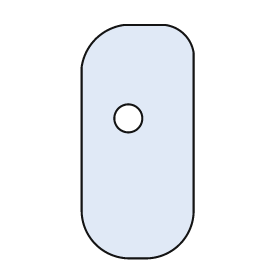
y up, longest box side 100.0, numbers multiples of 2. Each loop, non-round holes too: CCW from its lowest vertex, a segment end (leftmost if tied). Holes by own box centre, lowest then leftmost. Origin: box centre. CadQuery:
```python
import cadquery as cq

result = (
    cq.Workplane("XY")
    .moveTo(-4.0, -50.0)
    .lineTo(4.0, -50.0)
    .threePointArc((18.0, -44.0), (24.0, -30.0))
    .lineTo(24.0, 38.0)
    .threePointArc((20.0, 46.0), (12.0, 50.0))
    .lineTo(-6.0, 50.0)
    .threePointArc((-18.0, 44.0), (-24.0, 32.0))
    .lineTo(-24.0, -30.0)
    .threePointArc((-18.0, -44.0), (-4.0, -50.0))
    .close()
    .moveTo(-4.0, 10.0)
    .circle(6.0)
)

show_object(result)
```